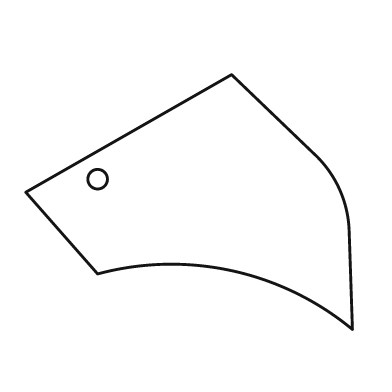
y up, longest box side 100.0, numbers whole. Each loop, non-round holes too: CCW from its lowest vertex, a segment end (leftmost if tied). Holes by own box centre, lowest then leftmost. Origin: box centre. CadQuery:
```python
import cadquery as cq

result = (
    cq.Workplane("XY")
    .moveTo(50.0, -39.0)
    .lineTo(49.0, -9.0)
    .threePointArc((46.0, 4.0), (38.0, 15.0))
    .lineTo(13.0, 39.0)
    .lineTo(-50.0, 3.0)
    .lineTo(-28.0, -22.0)
    .threePointArc((13.0, -21.0), (50.0, -39.0))
    .close()
    .moveTo(-28.0, 7.0)
    .circle(3.0)
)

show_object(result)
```